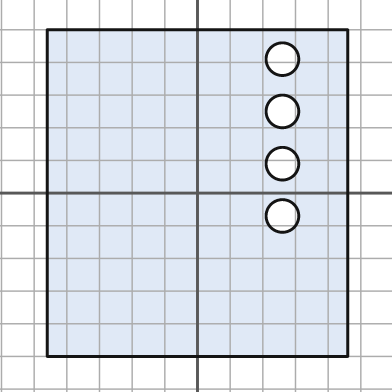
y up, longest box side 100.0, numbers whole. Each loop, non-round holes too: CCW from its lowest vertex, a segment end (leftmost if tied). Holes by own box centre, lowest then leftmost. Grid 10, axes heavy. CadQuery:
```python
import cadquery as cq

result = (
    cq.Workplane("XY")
    .moveTo(-46.0, -50.0)
    .lineTo(46.0, -50.0)
    .lineTo(46.0, 50.0)
    .lineTo(-46.0, 50.0)
    .close()
    .moveTo(26.0, -7.0)
    .circle(5.0)
    .moveTo(26.0, 9.0)
    .circle(5.0)
    .moveTo(26.0, 25.0)
    .circle(5.0)
    .moveTo(26.0, 41.0)
    .circle(5.0)
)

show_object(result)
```